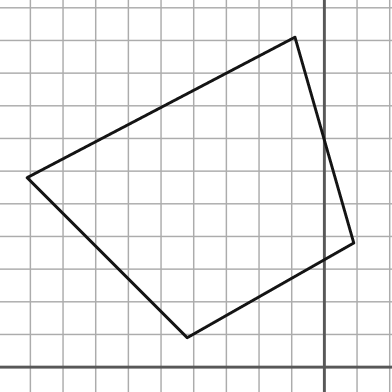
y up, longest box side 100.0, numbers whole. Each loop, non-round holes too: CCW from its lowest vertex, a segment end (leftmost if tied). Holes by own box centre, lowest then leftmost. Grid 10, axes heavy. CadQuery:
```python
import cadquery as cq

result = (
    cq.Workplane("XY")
    .moveTo(-42.0, 9.0)
    .lineTo(9.0, 38.0)
    .lineTo(-9.0, 101.0)
    .lineTo(-91.0, 58.0)
    .close()
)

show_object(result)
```